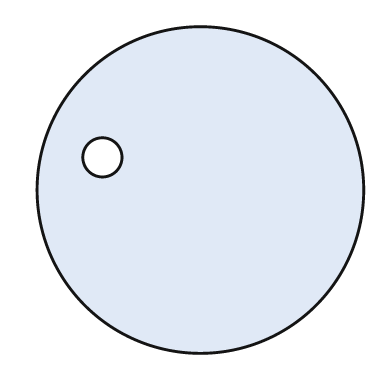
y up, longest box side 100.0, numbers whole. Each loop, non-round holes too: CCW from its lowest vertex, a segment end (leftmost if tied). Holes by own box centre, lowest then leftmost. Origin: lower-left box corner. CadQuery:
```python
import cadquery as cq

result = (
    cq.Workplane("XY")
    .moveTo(50.0, 50.0)
    .circle(50.0)
    .moveTo(20.0, 60.0)
    .circle(6.0)
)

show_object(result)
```